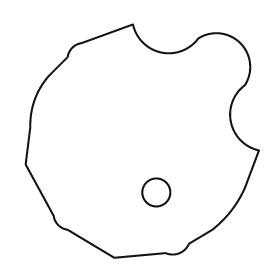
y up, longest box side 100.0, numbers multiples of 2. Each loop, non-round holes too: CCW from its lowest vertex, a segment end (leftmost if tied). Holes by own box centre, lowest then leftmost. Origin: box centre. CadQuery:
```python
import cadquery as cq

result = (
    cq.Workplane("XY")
    .moveTo(-12.0, -50.0)
    .lineTo(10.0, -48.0)
    .threePointArc((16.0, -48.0), (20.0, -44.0))
    .lineTo(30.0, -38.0)
    .threePointArc((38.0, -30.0), (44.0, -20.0))
    .lineTo(50.0, -4.0)
    .threePointArc((38.0, 8.0), (44.0, 24.0))
    .threePointArc((42.0, 42.0), (24.0, 44.0))
    .threePointArc((8.0, 38.0), (-4.0, 50.0))
    .lineTo(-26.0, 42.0)
    .threePointArc((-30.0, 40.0), (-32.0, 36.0))
    .lineTo(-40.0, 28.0)
    .threePointArc((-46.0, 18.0), (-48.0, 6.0))
    .lineTo(-50.0, -10.0)
    .lineTo(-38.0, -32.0)
    .threePointArc((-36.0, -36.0), (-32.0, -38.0))
    .close()
    .moveTo(6.0, -22.0)
    .circle(6.0)
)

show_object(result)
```